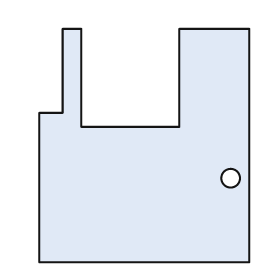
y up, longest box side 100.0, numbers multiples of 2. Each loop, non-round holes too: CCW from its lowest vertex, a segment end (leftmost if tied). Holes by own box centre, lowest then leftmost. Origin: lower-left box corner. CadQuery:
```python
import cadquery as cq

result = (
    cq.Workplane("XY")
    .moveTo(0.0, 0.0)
    .lineTo(90.0, 0.0)
    .lineTo(90.0, 100.0)
    .lineTo(60.0, 100.0)
    .lineTo(60.0, 58.0)
    .lineTo(18.0, 58.0)
    .lineTo(18.0, 100.0)
    .lineTo(10.0, 100.0)
    .lineTo(10.0, 64.0)
    .lineTo(0.0, 64.0)
    .close()
    .moveTo(82.0, 36.0)
    .circle(4.0)
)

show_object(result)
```